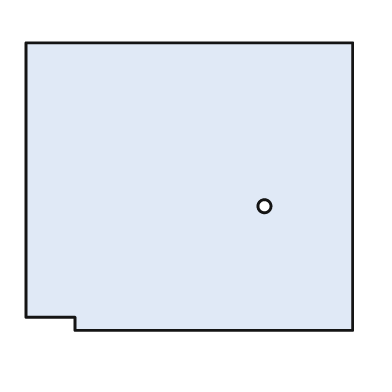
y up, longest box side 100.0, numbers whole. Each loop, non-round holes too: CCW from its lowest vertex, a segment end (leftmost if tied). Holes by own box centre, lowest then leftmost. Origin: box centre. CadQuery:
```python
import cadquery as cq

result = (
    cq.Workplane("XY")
    .moveTo(-35.0, -44.0)
    .lineTo(50.0, -44.0)
    .lineTo(50.0, 44.0)
    .lineTo(-50.0, 44.0)
    .lineTo(-50.0, -40.0)
    .lineTo(-35.0, -40.0)
    .close()
    .moveTo(23.0, -6.0)
    .circle(2.0)
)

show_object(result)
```